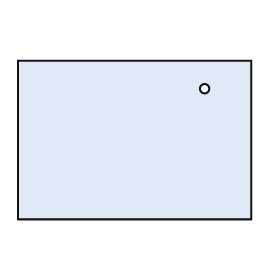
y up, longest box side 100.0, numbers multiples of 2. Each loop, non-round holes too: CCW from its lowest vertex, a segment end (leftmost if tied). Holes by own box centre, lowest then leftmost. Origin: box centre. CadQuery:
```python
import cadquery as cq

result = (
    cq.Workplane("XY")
    .moveTo(-50.0, -34.0)
    .lineTo(50.0, -34.0)
    .lineTo(50.0, 34.0)
    .lineTo(-50.0, 34.0)
    .close()
    .moveTo(30.0, 22.0)
    .circle(2.0)
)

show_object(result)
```